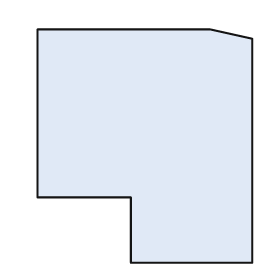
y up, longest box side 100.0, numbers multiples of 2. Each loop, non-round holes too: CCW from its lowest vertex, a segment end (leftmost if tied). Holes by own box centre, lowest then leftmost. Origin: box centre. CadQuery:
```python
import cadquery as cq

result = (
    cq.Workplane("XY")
    .moveTo(-6.0, -50.0)
    .lineTo(46.0, -50.0)
    .lineTo(46.0, 46.0)
    .lineTo(28.0, 50.0)
    .lineTo(-46.0, 50.0)
    .lineTo(-46.0, -22.0)
    .lineTo(-6.0, -22.0)
    .close()
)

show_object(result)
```